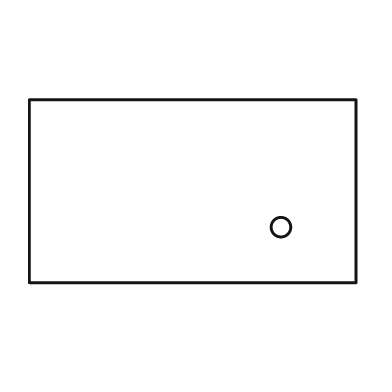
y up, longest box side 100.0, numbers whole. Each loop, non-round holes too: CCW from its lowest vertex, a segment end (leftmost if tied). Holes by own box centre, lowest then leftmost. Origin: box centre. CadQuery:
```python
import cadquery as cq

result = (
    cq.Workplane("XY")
    .moveTo(-50.0, -28.0)
    .lineTo(50.0, -28.0)
    .lineTo(50.0, 28.0)
    .lineTo(-50.0, 28.0)
    .close()
    .moveTo(27.0, -11.0)
    .circle(3.0)
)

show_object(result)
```